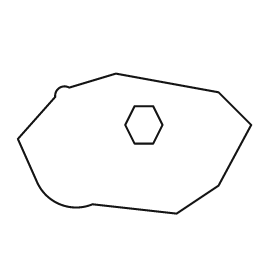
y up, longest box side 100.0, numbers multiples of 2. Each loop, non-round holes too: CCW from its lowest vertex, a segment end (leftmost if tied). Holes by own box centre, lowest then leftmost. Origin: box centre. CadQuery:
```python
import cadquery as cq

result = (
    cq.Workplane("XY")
    .moveTo(18.0, -30.0)
    .lineTo(36.0, -18.0)
    .lineTo(50.0, 8.0)
    .lineTo(36.0, 22.0)
    .lineTo(-8.0, 30.0)
    .lineTo(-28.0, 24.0)
    .threePointArc((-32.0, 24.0), (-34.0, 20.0))
    .lineTo(-50.0, 2.0)
    .lineTo(-42.0, -16.0)
    .threePointArc((-32.0, -26.0), (-18.0, -26.0))
    .close()
    .moveTo(0.0, 0.0)
    .lineTo(8.0, 0.0)
    .lineTo(12.0, 8.0)
    .lineTo(8.0, 16.0)
    .lineTo(0.0, 16.0)
    .lineTo(-4.0, 8.0)
    .close()
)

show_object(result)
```